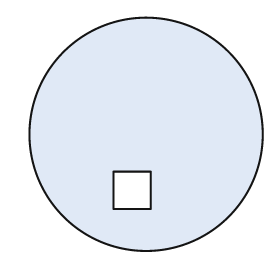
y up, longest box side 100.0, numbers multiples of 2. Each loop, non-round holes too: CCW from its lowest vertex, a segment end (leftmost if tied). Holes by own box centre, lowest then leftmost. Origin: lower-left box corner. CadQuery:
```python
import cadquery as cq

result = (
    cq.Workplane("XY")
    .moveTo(50.0, 50.0)
    .circle(50.0)
    .moveTo(36.0, 18.0)
    .lineTo(52.0, 18.0)
    .lineTo(52.0, 34.0)
    .lineTo(36.0, 34.0)
    .close()
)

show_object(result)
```